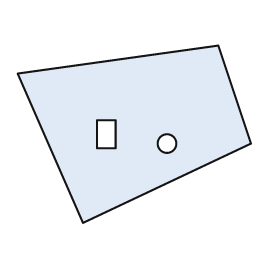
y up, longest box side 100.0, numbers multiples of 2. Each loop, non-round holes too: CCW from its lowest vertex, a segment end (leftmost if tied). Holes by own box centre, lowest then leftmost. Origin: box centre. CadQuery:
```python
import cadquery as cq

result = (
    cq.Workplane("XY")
    .moveTo(-22.0, -38.0)
    .lineTo(50.0, -4.0)
    .lineTo(36.0, 38.0)
    .lineTo(-50.0, 26.0)
    .close()
    .moveTo(14.0, -4.0)
    .circle(4.0)
    .moveTo(-16.0, -6.0)
    .lineTo(-8.0, -6.0)
    .lineTo(-8.0, 6.0)
    .lineTo(-16.0, 6.0)
    .close()
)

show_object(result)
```